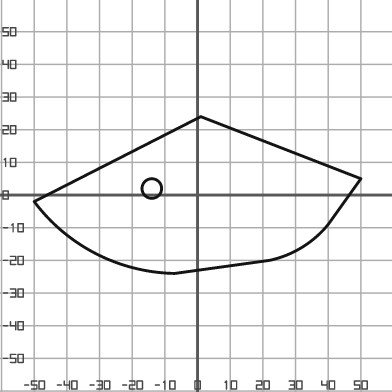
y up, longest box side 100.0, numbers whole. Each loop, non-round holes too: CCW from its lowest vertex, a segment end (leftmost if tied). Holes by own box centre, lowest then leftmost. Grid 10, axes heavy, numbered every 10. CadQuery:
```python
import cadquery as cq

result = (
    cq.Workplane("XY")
    .moveTo(-7.0, -24.0)
    .lineTo(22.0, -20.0)
    .threePointArc((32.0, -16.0), (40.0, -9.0))
    .lineTo(50.0, 5.0)
    .lineTo(1.0, 24.0)
    .lineTo(-50.0, -2.0)
    .threePointArc((-31.0, -18.0), (-7.0, -24.0))
    .close()
    .moveTo(-14.0, 2.0)
    .circle(3.0)
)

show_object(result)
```